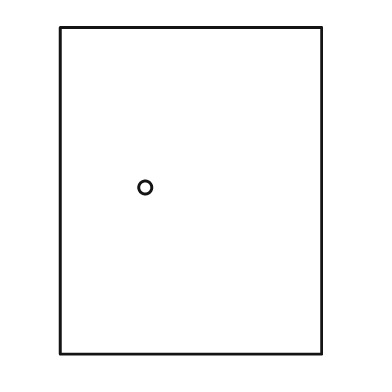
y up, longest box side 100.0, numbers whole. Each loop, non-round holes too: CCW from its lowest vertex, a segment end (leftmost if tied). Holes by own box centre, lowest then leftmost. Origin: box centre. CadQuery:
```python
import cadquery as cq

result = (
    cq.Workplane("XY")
    .moveTo(-40.0, -50.0)
    .lineTo(40.0, -50.0)
    .lineTo(40.0, 50.0)
    .lineTo(-40.0, 50.0)
    .close()
    .moveTo(-14.0, 1.0)
    .circle(2.0)
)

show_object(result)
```